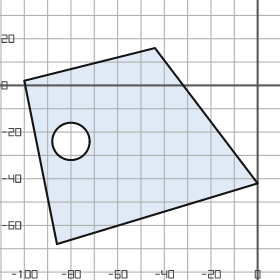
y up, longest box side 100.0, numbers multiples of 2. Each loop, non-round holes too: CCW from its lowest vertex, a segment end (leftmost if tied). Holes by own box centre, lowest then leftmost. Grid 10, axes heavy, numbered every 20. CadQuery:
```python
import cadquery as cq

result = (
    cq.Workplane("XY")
    .moveTo(-86.0, -68.0)
    .lineTo(0.0, -42.0)
    .lineTo(-44.0, 16.0)
    .lineTo(-100.0, 2.0)
    .close()
    .moveTo(-80.0, -24.0)
    .circle(8.0)
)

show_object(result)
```